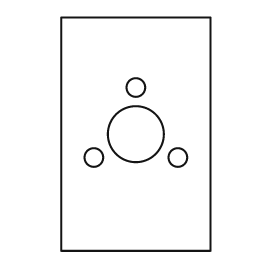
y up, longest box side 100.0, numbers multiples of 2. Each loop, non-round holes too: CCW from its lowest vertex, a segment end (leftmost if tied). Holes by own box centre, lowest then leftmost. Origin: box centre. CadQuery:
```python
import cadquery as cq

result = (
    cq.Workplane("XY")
    .moveTo(-32.0, -50.0)
    .lineTo(32.0, -50.0)
    .lineTo(32.0, 50.0)
    .lineTo(-32.0, 50.0)
    .close()
    .moveTo(-18.0, -10.0)
    .circle(4.0)
    .moveTo(18.0, -10.0)
    .circle(4.0)
    .moveTo(0.0, 0.0)
    .circle(12.0)
    .moveTo(0.0, 20.0)
    .circle(4.0)
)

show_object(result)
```